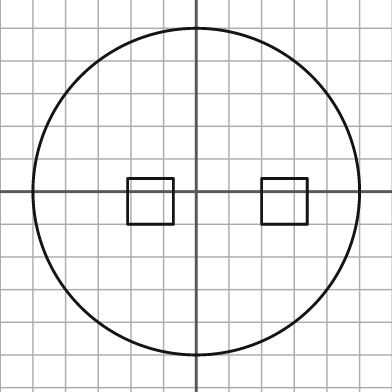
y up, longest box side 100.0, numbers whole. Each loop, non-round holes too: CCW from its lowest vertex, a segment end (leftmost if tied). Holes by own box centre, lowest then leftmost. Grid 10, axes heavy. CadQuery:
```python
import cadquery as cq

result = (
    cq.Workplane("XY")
    .moveTo(0.0, 0.0)
    .circle(50.0)
    .moveTo(-21.0, -10.0)
    .lineTo(-7.0, -10.0)
    .lineTo(-7.0, 4.0)
    .lineTo(-21.0, 4.0)
    .close()
    .moveTo(20.0, -10.0)
    .lineTo(34.0, -10.0)
    .lineTo(34.0, 4.0)
    .lineTo(20.0, 4.0)
    .close()
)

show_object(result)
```